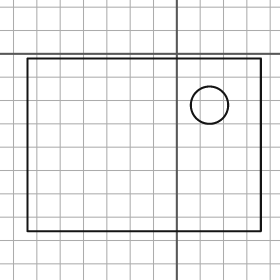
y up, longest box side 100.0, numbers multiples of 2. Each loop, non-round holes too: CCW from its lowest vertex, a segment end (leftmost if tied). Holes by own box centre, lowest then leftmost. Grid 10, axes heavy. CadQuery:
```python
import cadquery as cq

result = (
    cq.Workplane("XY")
    .moveTo(-64.0, -76.0)
    .lineTo(36.0, -76.0)
    .lineTo(36.0, -2.0)
    .lineTo(-64.0, -2.0)
    .close()
    .moveTo(14.0, -22.0)
    .circle(8.0)
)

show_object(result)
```